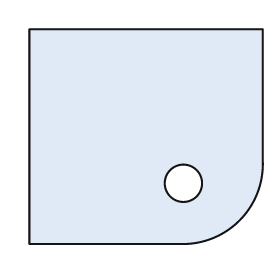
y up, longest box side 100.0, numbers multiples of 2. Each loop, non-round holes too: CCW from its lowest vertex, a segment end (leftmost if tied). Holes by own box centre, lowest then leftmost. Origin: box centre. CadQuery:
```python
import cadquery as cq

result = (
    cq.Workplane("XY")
    .moveTo(-50.0, -46.0)
    .lineTo(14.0, -46.0)
    .threePointArc((40.0, -36.0), (50.0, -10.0))
    .lineTo(50.0, 46.0)
    .lineTo(-50.0, 46.0)
    .close()
    .moveTo(16.0, -20.0)
    .circle(8.0)
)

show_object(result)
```